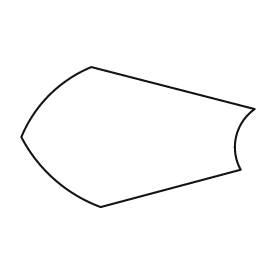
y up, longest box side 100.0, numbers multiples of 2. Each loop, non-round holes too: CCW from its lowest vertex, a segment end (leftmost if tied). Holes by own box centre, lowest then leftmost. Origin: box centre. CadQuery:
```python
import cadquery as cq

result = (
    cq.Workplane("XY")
    .moveTo(-16.0, -30.0)
    .lineTo(44.0, -14.0)
    .threePointArc((42.0, 0.0), (50.0, 12.0))
    .lineTo(-20.0, 30.0)
    .threePointArc((-38.0, 18.0), (-50.0, 0.0))
    .threePointArc((-36.0, -18.0), (-16.0, -30.0))
    .close()
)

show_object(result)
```